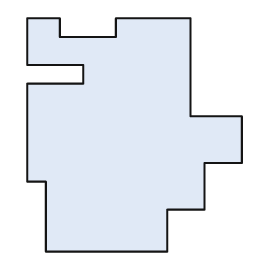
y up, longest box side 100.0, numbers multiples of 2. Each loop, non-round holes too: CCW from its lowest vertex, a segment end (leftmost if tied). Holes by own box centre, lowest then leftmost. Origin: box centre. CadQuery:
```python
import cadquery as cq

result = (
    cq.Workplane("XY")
    .moveTo(-38.0, -50.0)
    .lineTo(14.0, -50.0)
    .lineTo(14.0, -32.0)
    .lineTo(30.0, -32.0)
    .lineTo(30.0, -12.0)
    .lineTo(46.0, -12.0)
    .lineTo(46.0, 8.0)
    .lineTo(24.0, 8.0)
    .lineTo(24.0, 50.0)
    .lineTo(-8.0, 50.0)
    .lineTo(-8.0, 42.0)
    .lineTo(-32.0, 42.0)
    .lineTo(-32.0, 50.0)
    .lineTo(-46.0, 50.0)
    .lineTo(-46.0, 30.0)
    .lineTo(-22.0, 30.0)
    .lineTo(-22.0, 22.0)
    .lineTo(-46.0, 22.0)
    .lineTo(-46.0, -20.0)
    .lineTo(-38.0, -20.0)
    .close()
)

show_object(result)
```